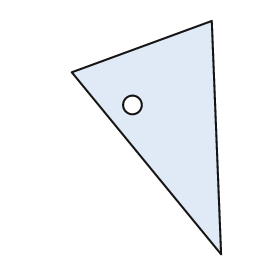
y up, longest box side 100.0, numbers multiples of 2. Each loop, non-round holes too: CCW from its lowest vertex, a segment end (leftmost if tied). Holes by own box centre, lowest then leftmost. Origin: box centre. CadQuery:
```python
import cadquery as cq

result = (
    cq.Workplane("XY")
    .moveTo(32.0, -50.0)
    .lineTo(28.0, 50.0)
    .lineTo(-32.0, 28.0)
    .close()
    .moveTo(-6.0, 14.0)
    .circle(4.0)
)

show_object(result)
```